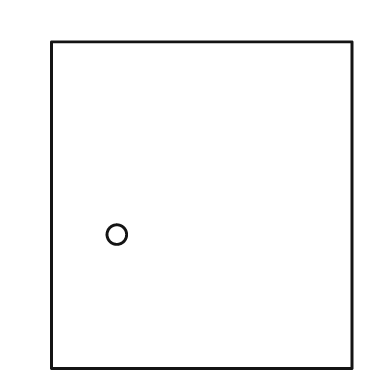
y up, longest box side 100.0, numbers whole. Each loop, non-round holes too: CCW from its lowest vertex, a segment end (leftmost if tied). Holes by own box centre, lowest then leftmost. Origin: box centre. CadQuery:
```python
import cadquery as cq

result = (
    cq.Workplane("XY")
    .moveTo(-46.0, -50.0)
    .lineTo(46.0, -50.0)
    .lineTo(46.0, 50.0)
    .lineTo(-46.0, 50.0)
    .close()
    .moveTo(-26.0, -9.0)
    .circle(3.0)
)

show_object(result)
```